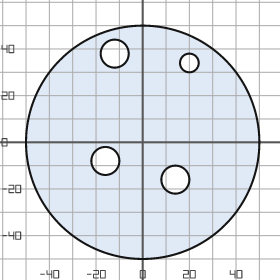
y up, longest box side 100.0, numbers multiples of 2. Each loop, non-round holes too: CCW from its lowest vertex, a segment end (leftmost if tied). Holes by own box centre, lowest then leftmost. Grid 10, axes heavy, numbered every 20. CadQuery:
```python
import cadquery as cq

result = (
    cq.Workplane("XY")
    .moveTo(0.0, 0.0)
    .circle(50.0)
    .moveTo(14.0, -16.0)
    .circle(6.0)
    .moveTo(-16.0, -8.0)
    .circle(6.0)
    .moveTo(20.0, 34.0)
    .circle(4.0)
    .moveTo(-12.0, 38.0)
    .circle(6.0)
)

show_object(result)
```